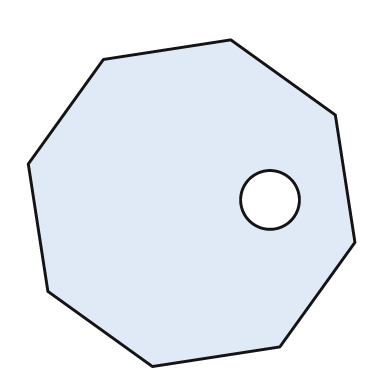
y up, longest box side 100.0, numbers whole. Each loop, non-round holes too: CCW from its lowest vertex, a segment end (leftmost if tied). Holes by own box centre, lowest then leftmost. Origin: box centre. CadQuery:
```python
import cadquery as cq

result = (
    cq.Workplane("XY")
    .moveTo(-12.0, -50.0)
    .lineTo(27.0, -44.0)
    .lineTo(50.0, -12.0)
    .lineTo(44.0, 27.0)
    .lineTo(12.0, 50.0)
    .lineTo(-27.0, 44.0)
    .lineTo(-50.0, 12.0)
    .lineTo(-44.0, -27.0)
    .close()
    .moveTo(24.0, 1.0)
    .circle(9.0)
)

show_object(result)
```